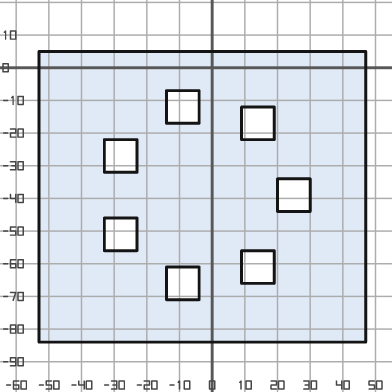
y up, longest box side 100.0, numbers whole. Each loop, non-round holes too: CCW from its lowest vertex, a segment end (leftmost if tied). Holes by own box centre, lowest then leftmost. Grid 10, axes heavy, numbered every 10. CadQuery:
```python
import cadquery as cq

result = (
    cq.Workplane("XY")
    .moveTo(-53.0, -84.0)
    .lineTo(47.0, -84.0)
    .lineTo(47.0, 5.0)
    .lineTo(-53.0, 5.0)
    .close()
    .moveTo(-14.0, -71.0)
    .lineTo(-4.0, -71.0)
    .lineTo(-4.0, -61.0)
    .lineTo(-14.0, -61.0)
    .close()
    .moveTo(9.0, -66.0)
    .lineTo(19.0, -66.0)
    .lineTo(19.0, -56.0)
    .lineTo(9.0, -56.0)
    .close()
    .moveTo(-33.0, -56.0)
    .lineTo(-23.0, -56.0)
    .lineTo(-23.0, -46.0)
    .lineTo(-33.0, -46.0)
    .close()
    .moveTo(20.0, -44.0)
    .lineTo(30.0, -44.0)
    .lineTo(30.0, -34.0)
    .lineTo(20.0, -34.0)
    .close()
    .moveTo(-33.0, -32.0)
    .lineTo(-23.0, -32.0)
    .lineTo(-23.0, -22.0)
    .lineTo(-33.0, -22.0)
    .close()
    .moveTo(9.0, -22.0)
    .lineTo(19.0, -22.0)
    .lineTo(19.0, -12.0)
    .lineTo(9.0, -12.0)
    .close()
    .moveTo(-14.0, -17.0)
    .lineTo(-4.0, -17.0)
    .lineTo(-4.0, -7.0)
    .lineTo(-14.0, -7.0)
    .close()
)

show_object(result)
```